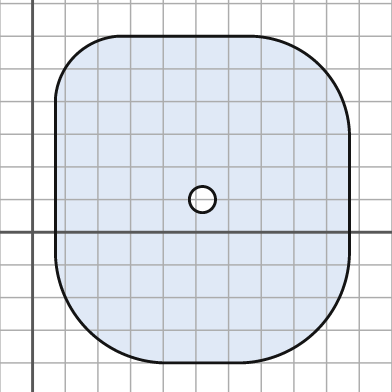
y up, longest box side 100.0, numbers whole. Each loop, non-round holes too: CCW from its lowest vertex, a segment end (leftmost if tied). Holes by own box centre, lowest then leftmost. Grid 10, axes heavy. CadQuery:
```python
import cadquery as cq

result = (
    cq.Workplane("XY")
    .moveTo(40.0, -40.0)
    .lineTo(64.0, -40.0)
    .threePointArc((87.0, -30.0), (97.0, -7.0))
    .lineTo(97.0, 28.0)
    .threePointArc((88.0, 51.0), (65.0, 60.0))
    .lineTo(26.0, 60.0)
    .threePointArc((13.0, 54.0), (7.0, 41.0))
    .lineTo(7.0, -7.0)
    .threePointArc((17.0, -30.0), (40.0, -40.0))
    .close()
    .moveTo(52.0, 10.0)
    .circle(4.0)
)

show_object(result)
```